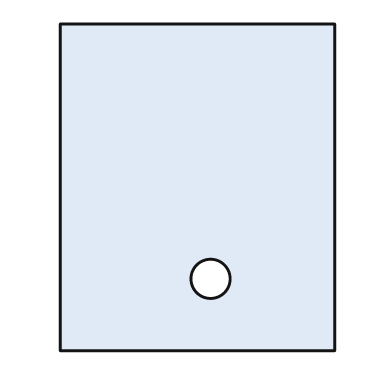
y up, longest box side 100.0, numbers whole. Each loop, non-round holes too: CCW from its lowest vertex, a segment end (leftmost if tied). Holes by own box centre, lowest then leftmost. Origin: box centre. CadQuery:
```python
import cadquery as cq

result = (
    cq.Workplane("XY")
    .moveTo(-42.0, -50.0)
    .lineTo(42.0, -50.0)
    .lineTo(42.0, 50.0)
    .lineTo(-42.0, 50.0)
    .close()
    .moveTo(4.0, -28.0)
    .circle(6.0)
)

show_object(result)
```